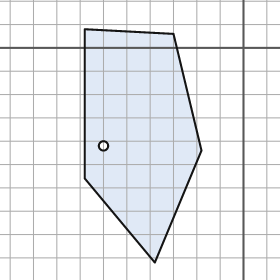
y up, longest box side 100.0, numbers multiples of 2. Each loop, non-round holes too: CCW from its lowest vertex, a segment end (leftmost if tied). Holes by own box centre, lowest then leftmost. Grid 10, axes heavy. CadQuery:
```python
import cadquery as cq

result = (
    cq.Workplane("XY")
    .moveTo(-38.0, -92.0)
    .lineTo(-18.0, -44.0)
    .lineTo(-30.0, 6.0)
    .lineTo(-68.0, 8.0)
    .lineTo(-68.0, -56.0)
    .close()
    .moveTo(-60.0, -42.0)
    .circle(2.0)
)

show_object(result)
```